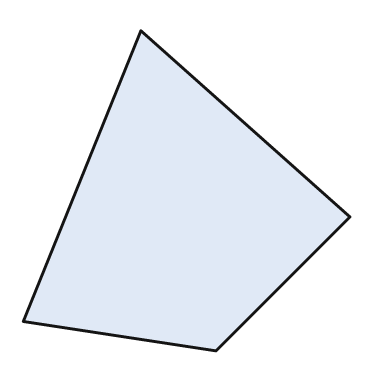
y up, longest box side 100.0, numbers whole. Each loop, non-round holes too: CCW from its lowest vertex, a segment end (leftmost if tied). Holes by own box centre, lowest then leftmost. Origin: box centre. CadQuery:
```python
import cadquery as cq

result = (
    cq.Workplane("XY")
    .moveTo(9.0, -49.0)
    .lineTo(50.0, -8.0)
    .lineTo(-14.0, 49.0)
    .lineTo(-50.0, -40.0)
    .close()
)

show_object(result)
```